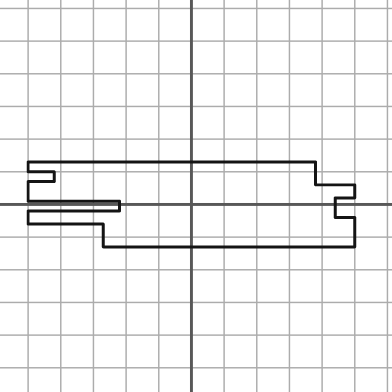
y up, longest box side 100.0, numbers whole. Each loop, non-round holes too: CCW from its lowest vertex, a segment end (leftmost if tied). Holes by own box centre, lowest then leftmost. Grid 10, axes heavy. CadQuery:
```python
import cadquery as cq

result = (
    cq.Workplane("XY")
    .moveTo(-27.0, -13.0)
    .lineTo(50.0, -13.0)
    .lineTo(50.0, -4.0)
    .lineTo(44.0, -4.0)
    .lineTo(44.0, 2.0)
    .lineTo(50.0, 2.0)
    .lineTo(50.0, 6.0)
    .lineTo(38.0, 6.0)
    .lineTo(38.0, 13.0)
    .lineTo(-50.0, 13.0)
    .lineTo(-50.0, 10.0)
    .lineTo(-42.0, 10.0)
    .lineTo(-42.0, 7.0)
    .lineTo(-50.0, 7.0)
    .lineTo(-50.0, 1.0)
    .lineTo(-22.0, 1.0)
    .lineTo(-22.0, -2.0)
    .lineTo(-50.0, -2.0)
    .lineTo(-50.0, -6.0)
    .lineTo(-27.0, -6.0)
    .close()
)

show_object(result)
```